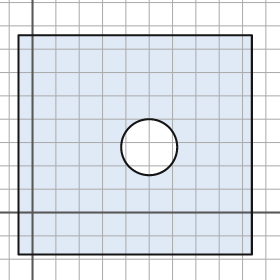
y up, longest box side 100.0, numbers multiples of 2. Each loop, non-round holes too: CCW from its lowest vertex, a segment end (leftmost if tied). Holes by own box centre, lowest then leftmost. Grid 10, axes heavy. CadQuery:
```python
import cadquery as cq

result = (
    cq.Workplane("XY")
    .moveTo(-6.0, -18.0)
    .lineTo(94.0, -18.0)
    .lineTo(94.0, 76.0)
    .lineTo(-6.0, 76.0)
    .close()
    .moveTo(50.0, 28.0)
    .circle(12.0)
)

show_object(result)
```